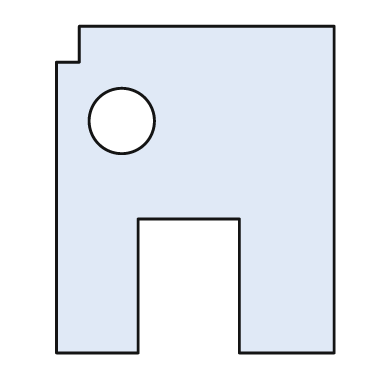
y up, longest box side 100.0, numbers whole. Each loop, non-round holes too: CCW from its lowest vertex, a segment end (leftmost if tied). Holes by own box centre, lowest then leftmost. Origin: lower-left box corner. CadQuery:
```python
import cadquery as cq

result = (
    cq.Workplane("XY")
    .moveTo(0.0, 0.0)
    .lineTo(25.0, 0.0)
    .lineTo(25.0, 41.0)
    .lineTo(56.0, 41.0)
    .lineTo(56.0, 0.0)
    .lineTo(85.0, 0.0)
    .lineTo(85.0, 100.0)
    .lineTo(7.0, 100.0)
    .lineTo(7.0, 89.0)
    .lineTo(0.0, 89.0)
    .close()
    .moveTo(20.0, 71.0)
    .circle(10.0)
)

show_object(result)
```